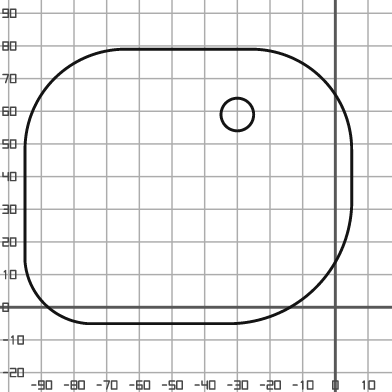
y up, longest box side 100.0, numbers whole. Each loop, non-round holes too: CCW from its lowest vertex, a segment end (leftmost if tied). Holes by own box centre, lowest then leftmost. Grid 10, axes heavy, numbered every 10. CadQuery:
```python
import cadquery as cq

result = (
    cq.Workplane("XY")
    .moveTo(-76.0, -5.0)
    .lineTo(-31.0, -5.0)
    .threePointArc((-6.0, 6.0), (5.0, 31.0))
    .lineTo(5.0, 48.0)
    .threePointArc((-4.0, 70.0), (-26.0, 79.0))
    .lineTo(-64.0, 79.0)
    .threePointArc((-86.0, 70.0), (-95.0, 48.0))
    .lineTo(-95.0, 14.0)
    .threePointArc((-89.0, 1.0), (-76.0, -5.0))
    .close()
    .moveTo(-30.0, 59.0)
    .circle(5.0)
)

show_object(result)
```